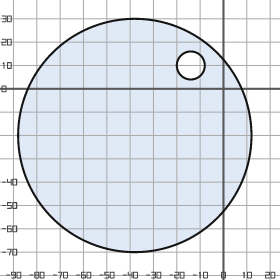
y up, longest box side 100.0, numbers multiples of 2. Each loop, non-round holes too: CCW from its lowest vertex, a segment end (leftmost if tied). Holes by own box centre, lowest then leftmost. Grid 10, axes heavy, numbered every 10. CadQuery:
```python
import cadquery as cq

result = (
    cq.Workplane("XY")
    .moveTo(-38.0, -20.0)
    .circle(50.0)
    .moveTo(-14.0, 10.0)
    .circle(6.0)
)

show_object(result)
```